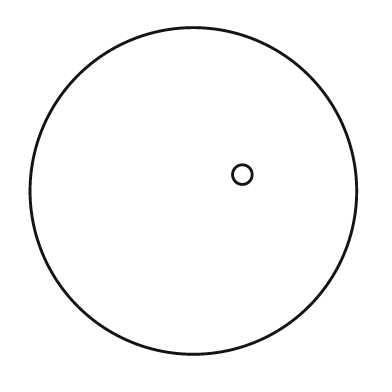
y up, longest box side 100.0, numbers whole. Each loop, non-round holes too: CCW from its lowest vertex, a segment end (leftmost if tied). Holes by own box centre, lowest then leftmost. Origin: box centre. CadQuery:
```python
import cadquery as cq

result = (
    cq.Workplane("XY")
    .moveTo(0.0, 0.0)
    .circle(50.0)
    .moveTo(15.0, 5.0)
    .circle(3.0)
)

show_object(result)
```